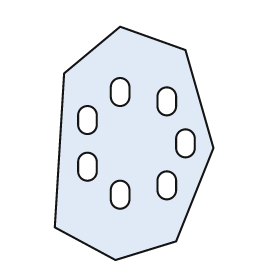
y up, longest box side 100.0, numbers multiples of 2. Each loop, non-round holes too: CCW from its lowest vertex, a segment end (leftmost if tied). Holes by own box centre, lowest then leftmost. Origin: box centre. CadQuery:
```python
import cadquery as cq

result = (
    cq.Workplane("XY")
    .moveTo(-8.0, -50.0)
    .lineTo(18.0, -42.0)
    .lineTo(34.0, -2.0)
    .lineTo(22.0, 40.0)
    .lineTo(-6.0, 50.0)
    .lineTo(-30.0, 30.0)
    .lineTo(-34.0, -36.0)
    .close()
    .moveTo(-10.0, -24.0)
    .threePointArc((-6.0, -28.0), (-2.0, -24.0))
    .lineTo(-2.0, -20.0)
    .threePointArc((-6.0, -16.0), (-10.0, -20.0))
    .close()
    .moveTo(10.0, -20.0)
    .threePointArc((14.0, -24.0), (18.0, -20.0))
    .lineTo(18.0, -16.0)
    .threePointArc((14.0, -12.0), (10.0, -16.0))
    .close()
    .moveTo(-24.0, -12.0)
    .threePointArc((-20.0, -16.0), (-16.0, -12.0))
    .lineTo(-16.0, -8.0)
    .threePointArc((-20.0, -4.0), (-24.0, -8.0))
    .close()
    .moveTo(18.0, -2.0)
    .threePointArc((22.0, -6.0), (26.0, -2.0))
    .lineTo(26.0, 2.0)
    .threePointArc((22.0, 6.0), (18.0, 2.0))
    .close()
    .moveTo(-24.0, 8.0)
    .threePointArc((-20.0, 4.0), (-16.0, 8.0))
    .lineTo(-16.0, 12.0)
    .threePointArc((-20.0, 16.0), (-24.0, 12.0))
    .close()
    .moveTo(10.0, 16.0)
    .threePointArc((14.0, 12.0), (18.0, 16.0))
    .lineTo(18.0, 20.0)
    .threePointArc((14.0, 24.0), (10.0, 20.0))
    .close()
    .moveTo(-10.0, 20.0)
    .threePointArc((-6.0, 16.0), (-2.0, 20.0))
    .lineTo(-2.0, 24.0)
    .threePointArc((-6.0, 28.0), (-10.0, 24.0))
    .close()
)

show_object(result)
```